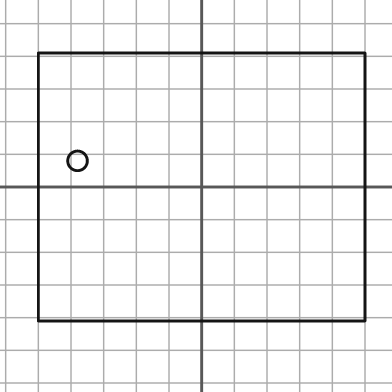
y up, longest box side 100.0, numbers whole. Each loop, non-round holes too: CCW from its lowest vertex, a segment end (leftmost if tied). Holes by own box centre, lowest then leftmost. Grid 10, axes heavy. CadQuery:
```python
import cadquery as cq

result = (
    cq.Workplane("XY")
    .moveTo(-50.0, -41.0)
    .lineTo(50.0, -41.0)
    .lineTo(50.0, 41.0)
    .lineTo(-50.0, 41.0)
    .close()
    .moveTo(-38.0, 8.0)
    .circle(3.0)
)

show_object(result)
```